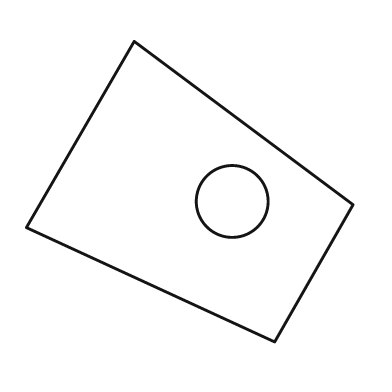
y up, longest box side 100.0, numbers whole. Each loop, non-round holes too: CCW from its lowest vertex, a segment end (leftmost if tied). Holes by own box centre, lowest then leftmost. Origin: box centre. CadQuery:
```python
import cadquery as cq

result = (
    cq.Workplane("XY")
    .moveTo(26.0, -46.0)
    .lineTo(50.0, -4.0)
    .lineTo(-17.0, 46.0)
    .lineTo(-50.0, -11.0)
    .close()
    .moveTo(13.0, -3.0)
    .circle(11.0)
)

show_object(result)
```